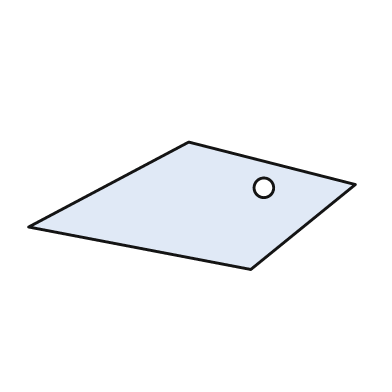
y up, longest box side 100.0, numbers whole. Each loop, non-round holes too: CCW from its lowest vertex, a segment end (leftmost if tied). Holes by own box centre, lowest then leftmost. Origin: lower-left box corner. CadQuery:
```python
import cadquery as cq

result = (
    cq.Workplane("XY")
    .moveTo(68.0, 0.0)
    .lineTo(100.0, 26.0)
    .lineTo(49.0, 39.0)
    .lineTo(0.0, 13.0)
    .close()
    .moveTo(72.0, 25.0)
    .circle(3.0)
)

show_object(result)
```